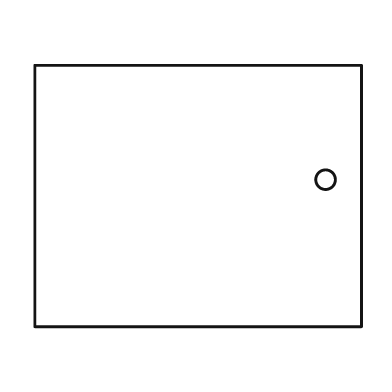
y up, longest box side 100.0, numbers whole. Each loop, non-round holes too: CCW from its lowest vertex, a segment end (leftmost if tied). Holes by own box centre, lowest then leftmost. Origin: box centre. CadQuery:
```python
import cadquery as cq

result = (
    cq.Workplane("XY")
    .moveTo(-50.0, -40.0)
    .lineTo(50.0, -40.0)
    .lineTo(50.0, 40.0)
    .lineTo(-50.0, 40.0)
    .close()
    .moveTo(39.0, 5.0)
    .circle(3.0)
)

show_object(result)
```